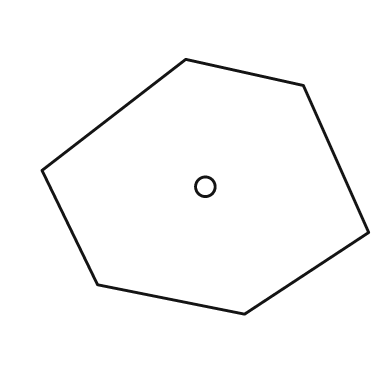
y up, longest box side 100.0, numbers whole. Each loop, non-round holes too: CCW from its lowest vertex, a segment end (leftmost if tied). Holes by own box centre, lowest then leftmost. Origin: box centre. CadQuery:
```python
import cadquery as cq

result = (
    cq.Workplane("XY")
    .moveTo(12.0, -39.0)
    .lineTo(50.0, -14.0)
    .lineTo(30.0, 31.0)
    .lineTo(-6.0, 39.0)
    .lineTo(-50.0, 5.0)
    .lineTo(-33.0, -30.0)
    .close()
    .moveTo(0.0, 0.0)
    .circle(3.0)
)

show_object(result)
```